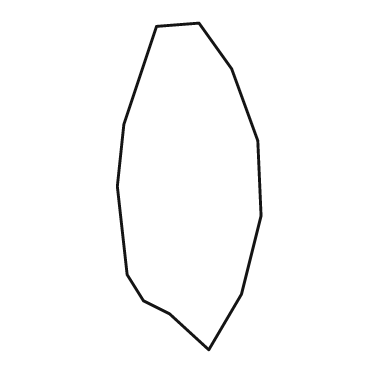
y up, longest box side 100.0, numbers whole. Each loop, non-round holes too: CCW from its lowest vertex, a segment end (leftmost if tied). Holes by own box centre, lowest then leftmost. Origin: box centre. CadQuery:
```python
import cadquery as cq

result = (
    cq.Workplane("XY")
    .moveTo(6.0, -50.0)
    .lineTo(16.0, -33.0)
    .lineTo(22.0, -9.0)
    .lineTo(21.0, 14.0)
    .lineTo(13.0, 36.0)
    .lineTo(3.0, 50.0)
    .lineTo(-10.0, 49.0)
    .lineTo(-20.0, 19.0)
    .lineTo(-22.0, 0.0)
    .lineTo(-19.0, -27.0)
    .lineTo(-14.0, -35.0)
    .lineTo(-6.0, -39.0)
    .close()
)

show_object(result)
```